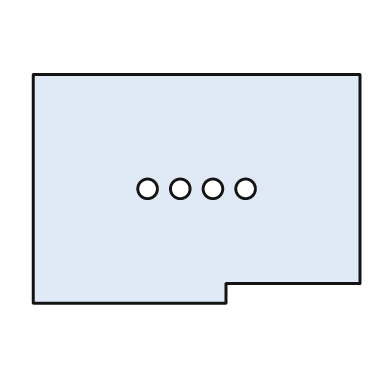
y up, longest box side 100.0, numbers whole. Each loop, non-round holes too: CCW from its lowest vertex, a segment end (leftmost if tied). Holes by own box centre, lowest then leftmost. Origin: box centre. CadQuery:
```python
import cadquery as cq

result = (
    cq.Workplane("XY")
    .moveTo(-50.0, -35.0)
    .lineTo(9.0, -35.0)
    .lineTo(9.0, -29.0)
    .lineTo(50.0, -29.0)
    .lineTo(50.0, 35.0)
    .lineTo(-50.0, 35.0)
    .close()
    .moveTo(-15.0, 0.0)
    .circle(3.0)
    .moveTo(-5.0, 0.0)
    .circle(3.0)
    .moveTo(5.0, 0.0)
    .circle(3.0)
    .moveTo(15.0, 0.0)
    .circle(3.0)
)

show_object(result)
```